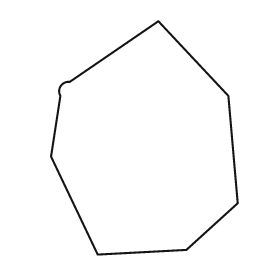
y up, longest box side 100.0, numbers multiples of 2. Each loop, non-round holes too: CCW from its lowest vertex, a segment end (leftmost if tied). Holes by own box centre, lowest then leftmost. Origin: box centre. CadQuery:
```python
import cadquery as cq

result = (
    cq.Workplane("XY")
    .moveTo(-20.0, -50.0)
    .lineTo(18.0, -48.0)
    .lineTo(40.0, -28.0)
    .lineTo(36.0, 18.0)
    .lineTo(6.0, 50.0)
    .lineTo(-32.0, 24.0)
    .threePointArc((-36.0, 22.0), (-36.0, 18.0))
    .lineTo(-40.0, -8.0)
    .close()
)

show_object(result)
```